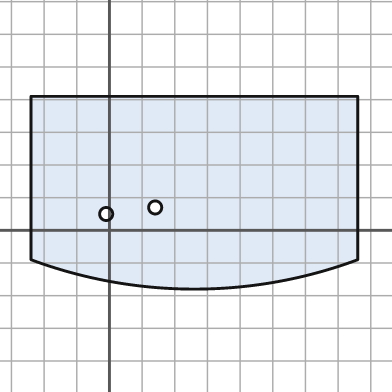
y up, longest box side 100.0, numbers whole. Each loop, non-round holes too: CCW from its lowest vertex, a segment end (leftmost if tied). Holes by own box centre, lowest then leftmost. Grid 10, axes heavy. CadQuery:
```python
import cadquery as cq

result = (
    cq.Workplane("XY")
    .moveTo(-24.0, -9.0)
    .threePointArc((26.0, -18.0), (76.0, -9.0))
    .lineTo(76.0, 41.0)
    .lineTo(-24.0, 41.0)
    .close()
    .moveTo(-1.0, 5.0)
    .circle(2.0)
    .moveTo(14.0, 7.0)
    .circle(2.0)
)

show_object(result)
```